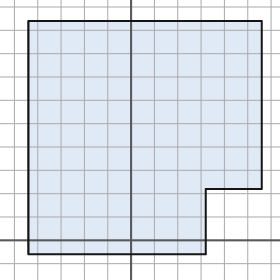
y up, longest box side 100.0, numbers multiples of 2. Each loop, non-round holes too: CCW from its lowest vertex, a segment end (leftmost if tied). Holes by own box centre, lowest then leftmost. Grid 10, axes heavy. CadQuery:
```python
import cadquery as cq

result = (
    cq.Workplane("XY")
    .moveTo(-44.0, -6.0)
    .lineTo(32.0, -6.0)
    .lineTo(32.0, 22.0)
    .lineTo(56.0, 22.0)
    .lineTo(56.0, 94.0)
    .lineTo(-44.0, 94.0)
    .close()
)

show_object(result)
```